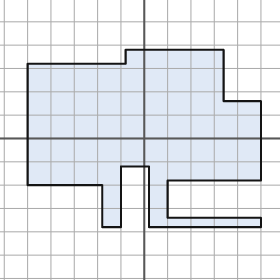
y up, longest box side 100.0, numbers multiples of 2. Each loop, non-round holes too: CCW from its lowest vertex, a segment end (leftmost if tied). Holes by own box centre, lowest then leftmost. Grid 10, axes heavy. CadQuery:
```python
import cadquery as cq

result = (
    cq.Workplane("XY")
    .moveTo(-18.0, -38.0)
    .lineTo(-10.0, -38.0)
    .lineTo(-10.0, -12.0)
    .lineTo(2.0, -12.0)
    .lineTo(2.0, -38.0)
    .lineTo(50.0, -38.0)
    .lineTo(50.0, -34.0)
    .lineTo(10.0, -34.0)
    .lineTo(10.0, -18.0)
    .lineTo(50.0, -18.0)
    .lineTo(50.0, 16.0)
    .lineTo(34.0, 16.0)
    .lineTo(34.0, 38.0)
    .lineTo(-8.0, 38.0)
    .lineTo(-8.0, 32.0)
    .lineTo(-50.0, 32.0)
    .lineTo(-50.0, -20.0)
    .lineTo(-18.0, -20.0)
    .close()
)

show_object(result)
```